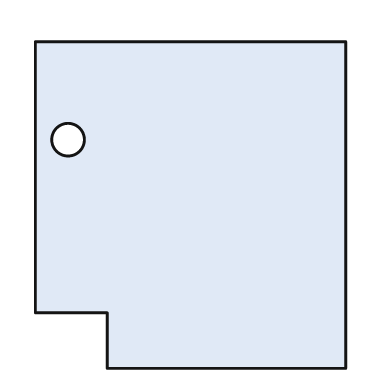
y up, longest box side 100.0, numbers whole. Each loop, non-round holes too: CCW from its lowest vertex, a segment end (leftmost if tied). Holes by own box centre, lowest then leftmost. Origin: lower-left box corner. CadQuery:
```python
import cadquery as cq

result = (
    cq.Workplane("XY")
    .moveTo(22.0, 0.0)
    .lineTo(95.0, 0.0)
    .lineTo(95.0, 100.0)
    .lineTo(0.0, 100.0)
    .lineTo(0.0, 17.0)
    .lineTo(22.0, 17.0)
    .close()
    .moveTo(10.0, 70.0)
    .circle(5.0)
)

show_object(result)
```